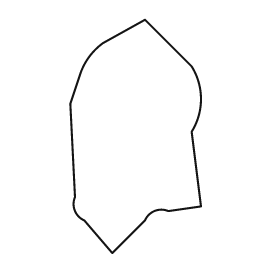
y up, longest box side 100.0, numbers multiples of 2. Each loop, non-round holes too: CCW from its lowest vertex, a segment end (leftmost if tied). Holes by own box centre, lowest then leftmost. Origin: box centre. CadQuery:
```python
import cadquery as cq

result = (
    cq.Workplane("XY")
    .moveTo(-10.0, -50.0)
    .lineTo(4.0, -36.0)
    .threePointArc((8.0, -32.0), (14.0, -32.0))
    .lineTo(28.0, -30.0)
    .lineTo(24.0, 2.0)
    .threePointArc((28.0, 16.0), (24.0, 30.0))
    .lineTo(4.0, 50.0)
    .lineTo(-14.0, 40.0)
    .threePointArc((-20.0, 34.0), (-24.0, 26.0))
    .lineTo(-28.0, 14.0)
    .lineTo(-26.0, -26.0)
    .threePointArc((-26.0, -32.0), (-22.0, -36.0))
    .close()
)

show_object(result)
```